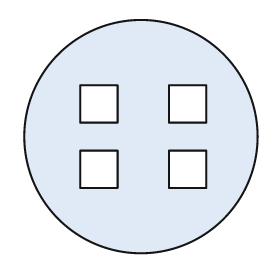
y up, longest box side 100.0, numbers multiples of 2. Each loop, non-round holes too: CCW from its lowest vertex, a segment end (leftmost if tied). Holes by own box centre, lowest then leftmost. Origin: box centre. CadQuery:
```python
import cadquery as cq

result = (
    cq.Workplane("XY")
    .moveTo(0.0, 0.0)
    .circle(50.0)
    .moveTo(-26.0, -22.0)
    .lineTo(-10.0, -22.0)
    .lineTo(-10.0, -6.0)
    .lineTo(-26.0, -6.0)
    .close()
    .moveTo(12.0, -22.0)
    .lineTo(28.0, -22.0)
    .lineTo(28.0, -6.0)
    .lineTo(12.0, -6.0)
    .close()
    .moveTo(-26.0, 6.0)
    .lineTo(-10.0, 6.0)
    .lineTo(-10.0, 22.0)
    .lineTo(-26.0, 22.0)
    .close()
    .moveTo(12.0, 6.0)
    .lineTo(28.0, 6.0)
    .lineTo(28.0, 22.0)
    .lineTo(12.0, 22.0)
    .close()
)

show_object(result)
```